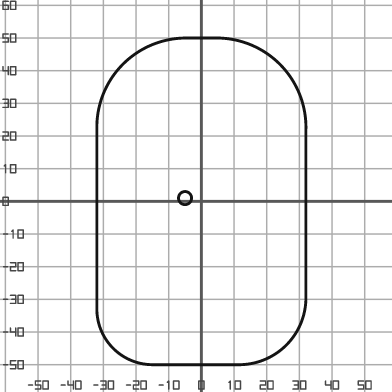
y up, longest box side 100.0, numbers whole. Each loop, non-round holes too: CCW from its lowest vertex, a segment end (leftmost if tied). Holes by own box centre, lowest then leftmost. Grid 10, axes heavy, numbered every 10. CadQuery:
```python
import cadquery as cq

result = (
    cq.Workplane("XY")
    .moveTo(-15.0, -50.0)
    .lineTo(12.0, -50.0)
    .threePointArc((26.0, -44.0), (32.0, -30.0))
    .lineTo(32.0, 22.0)
    .threePointArc((24.0, 42.0), (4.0, 50.0))
    .lineTo(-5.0, 50.0)
    .threePointArc((-24.0, 42.0), (-32.0, 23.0))
    .lineTo(-32.0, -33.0)
    .threePointArc((-27.0, -45.0), (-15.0, -50.0))
    .close()
    .moveTo(-5.0, 1.0)
    .circle(2.0)
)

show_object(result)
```